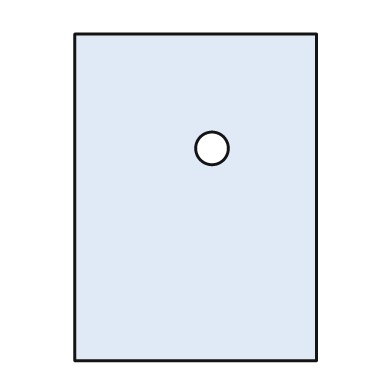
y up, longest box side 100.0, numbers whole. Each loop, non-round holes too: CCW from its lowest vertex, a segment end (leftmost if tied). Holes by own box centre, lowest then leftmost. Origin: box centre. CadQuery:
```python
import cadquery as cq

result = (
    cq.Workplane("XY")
    .moveTo(-37.0, -50.0)
    .lineTo(37.0, -50.0)
    .lineTo(37.0, 50.0)
    .lineTo(-37.0, 50.0)
    .close()
    .moveTo(5.0, 15.0)
    .circle(5.0)
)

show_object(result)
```